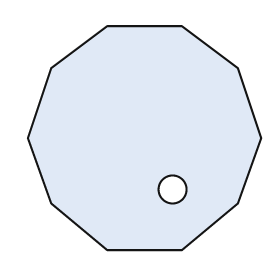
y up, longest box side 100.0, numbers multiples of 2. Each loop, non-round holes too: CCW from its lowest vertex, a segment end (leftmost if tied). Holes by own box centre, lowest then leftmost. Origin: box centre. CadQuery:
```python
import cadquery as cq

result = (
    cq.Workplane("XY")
    .moveTo(-16.0, -48.0)
    .lineTo(16.0, -48.0)
    .lineTo(40.0, -28.0)
    .lineTo(50.0, 0.0)
    .lineTo(40.0, 30.0)
    .lineTo(16.0, 48.0)
    .lineTo(-16.0, 48.0)
    .lineTo(-40.0, 30.0)
    .lineTo(-50.0, 0.0)
    .lineTo(-40.0, -28.0)
    .close()
    .moveTo(12.0, -22.0)
    .circle(6.0)
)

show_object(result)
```